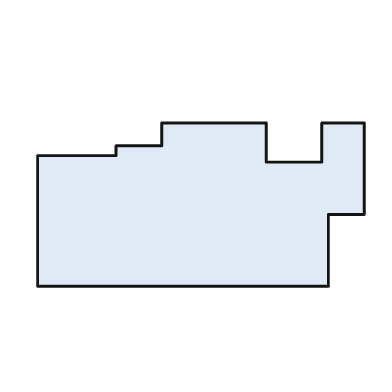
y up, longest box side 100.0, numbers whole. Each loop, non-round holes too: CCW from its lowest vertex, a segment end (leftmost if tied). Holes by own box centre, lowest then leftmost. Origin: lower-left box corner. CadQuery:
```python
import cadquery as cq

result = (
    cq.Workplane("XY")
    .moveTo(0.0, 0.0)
    .lineTo(89.0, 0.0)
    .lineTo(89.0, 22.0)
    .lineTo(100.0, 22.0)
    .lineTo(100.0, 50.0)
    .lineTo(87.0, 50.0)
    .lineTo(87.0, 38.0)
    .lineTo(70.0, 38.0)
    .lineTo(70.0, 50.0)
    .lineTo(38.0, 50.0)
    .lineTo(38.0, 43.0)
    .lineTo(24.0, 43.0)
    .lineTo(24.0, 40.0)
    .lineTo(0.0, 40.0)
    .close()
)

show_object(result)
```